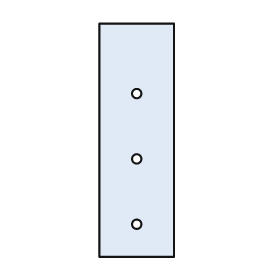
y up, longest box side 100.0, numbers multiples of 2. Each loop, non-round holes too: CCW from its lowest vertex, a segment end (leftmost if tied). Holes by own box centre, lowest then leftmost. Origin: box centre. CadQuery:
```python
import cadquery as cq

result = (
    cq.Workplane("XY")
    .moveTo(-16.0, -50.0)
    .lineTo(16.0, -50.0)
    .lineTo(16.0, 50.0)
    .lineTo(-16.0, 50.0)
    .close()
    .moveTo(0.0, -36.0)
    .circle(2.0)
    .moveTo(0.0, -8.0)
    .circle(2.0)
    .moveTo(0.0, 20.0)
    .circle(2.0)
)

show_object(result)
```